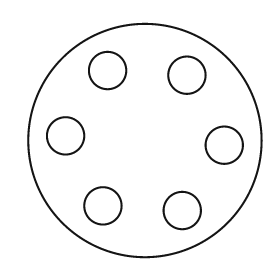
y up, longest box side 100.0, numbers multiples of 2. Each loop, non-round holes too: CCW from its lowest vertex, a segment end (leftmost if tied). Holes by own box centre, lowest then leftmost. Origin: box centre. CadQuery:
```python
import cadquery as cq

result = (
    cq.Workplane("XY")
    .moveTo(0.0, 0.0)
    .circle(50.0)
    .moveTo(16.0, -30.0)
    .circle(8.0)
    .moveTo(-18.0, -28.0)
    .circle(8.0)
    .moveTo(34.0, -2.0)
    .circle(8.0)
    .moveTo(-34.0, 2.0)
    .circle(8.0)
    .moveTo(18.0, 28.0)
    .circle(8.0)
    .moveTo(-16.0, 30.0)
    .circle(8.0)
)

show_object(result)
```